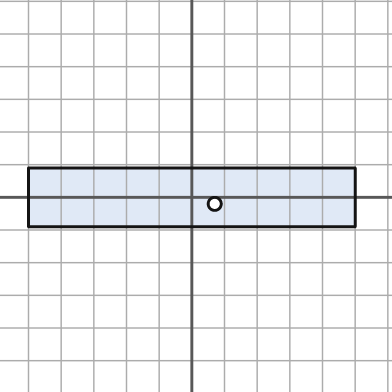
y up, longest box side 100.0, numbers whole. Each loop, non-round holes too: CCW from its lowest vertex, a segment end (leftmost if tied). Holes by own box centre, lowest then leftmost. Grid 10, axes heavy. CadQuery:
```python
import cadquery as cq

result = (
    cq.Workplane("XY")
    .moveTo(-50.0, -9.0)
    .lineTo(50.0, -9.0)
    .lineTo(50.0, 9.0)
    .lineTo(-50.0, 9.0)
    .close()
    .moveTo(7.0, -2.0)
    .circle(2.0)
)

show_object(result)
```